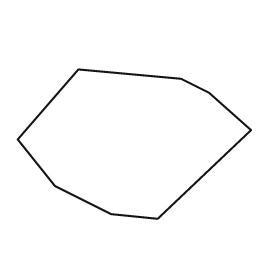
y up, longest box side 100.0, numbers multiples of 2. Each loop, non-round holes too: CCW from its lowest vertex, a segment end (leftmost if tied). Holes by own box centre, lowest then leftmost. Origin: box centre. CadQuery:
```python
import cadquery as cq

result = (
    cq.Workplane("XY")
    .moveTo(10.0, -32.0)
    .lineTo(50.0, 6.0)
    .lineTo(32.0, 22.0)
    .lineTo(20.0, 28.0)
    .lineTo(-24.0, 32.0)
    .lineTo(-50.0, 2.0)
    .lineTo(-34.0, -18.0)
    .lineTo(-10.0, -30.0)
    .close()
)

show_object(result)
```